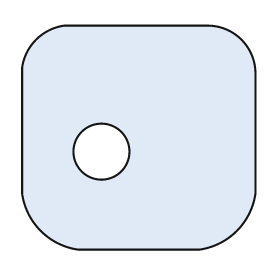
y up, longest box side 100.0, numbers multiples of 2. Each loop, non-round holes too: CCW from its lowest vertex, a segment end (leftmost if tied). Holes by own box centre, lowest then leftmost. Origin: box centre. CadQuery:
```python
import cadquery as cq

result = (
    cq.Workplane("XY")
    .moveTo(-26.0, -48.0)
    .lineTo(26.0, -48.0)
    .threePointArc((42.0, -40.0), (50.0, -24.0))
    .lineTo(50.0, 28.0)
    .threePointArc((44.0, 42.0), (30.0, 48.0))
    .lineTo(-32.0, 48.0)
    .threePointArc((-44.0, 42.0), (-50.0, 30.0))
    .lineTo(-50.0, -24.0)
    .threePointArc((-42.0, -40.0), (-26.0, -48.0))
    .close()
    .moveTo(-16.0, -6.0)
    .circle(12.0)
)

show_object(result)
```